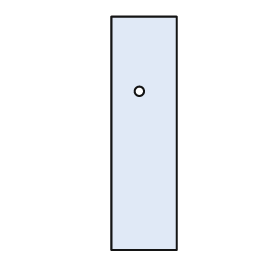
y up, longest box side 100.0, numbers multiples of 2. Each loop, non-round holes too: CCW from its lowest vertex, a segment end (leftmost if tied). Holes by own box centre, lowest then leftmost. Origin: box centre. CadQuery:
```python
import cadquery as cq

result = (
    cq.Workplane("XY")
    .moveTo(-14.0, -50.0)
    .lineTo(14.0, -50.0)
    .lineTo(14.0, 50.0)
    .lineTo(-14.0, 50.0)
    .close()
    .moveTo(-2.0, 18.0)
    .circle(2.0)
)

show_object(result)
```